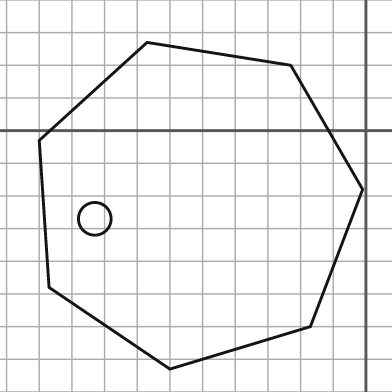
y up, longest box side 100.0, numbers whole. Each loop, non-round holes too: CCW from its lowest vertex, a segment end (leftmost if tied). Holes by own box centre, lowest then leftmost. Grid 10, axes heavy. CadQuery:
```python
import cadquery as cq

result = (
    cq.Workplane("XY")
    .moveTo(-60.0, -73.0)
    .lineTo(-17.0, -60.0)
    .lineTo(-1.0, -18.0)
    .lineTo(-23.0, 20.0)
    .lineTo(-67.0, 27.0)
    .lineTo(-100.0, -3.0)
    .lineTo(-97.0, -48.0)
    .close()
    .moveTo(-83.0, -27.0)
    .circle(5.0)
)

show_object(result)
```